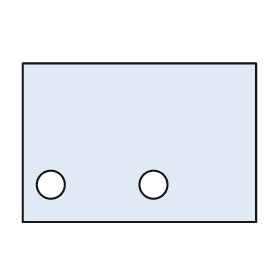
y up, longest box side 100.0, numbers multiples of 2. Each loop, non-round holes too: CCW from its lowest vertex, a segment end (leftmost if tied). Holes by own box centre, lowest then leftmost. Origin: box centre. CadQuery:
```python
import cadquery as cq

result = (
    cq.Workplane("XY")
    .moveTo(-50.0, -34.0)
    .lineTo(50.0, -34.0)
    .lineTo(50.0, 34.0)
    .lineTo(-50.0, 34.0)
    .close()
    .moveTo(-38.0, -18.0)
    .circle(6.0)
    .moveTo(6.0, -18.0)
    .circle(6.0)
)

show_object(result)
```